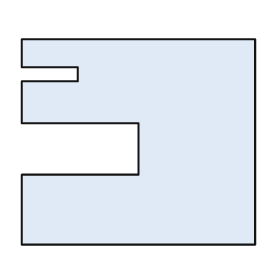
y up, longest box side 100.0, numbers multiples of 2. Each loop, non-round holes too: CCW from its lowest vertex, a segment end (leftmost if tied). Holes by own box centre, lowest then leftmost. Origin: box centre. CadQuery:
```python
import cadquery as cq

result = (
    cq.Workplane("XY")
    .moveTo(-50.0, -44.0)
    .lineTo(50.0, -44.0)
    .lineTo(50.0, 44.0)
    .lineTo(-50.0, 44.0)
    .lineTo(-50.0, 32.0)
    .lineTo(-26.0, 32.0)
    .lineTo(-26.0, 26.0)
    .lineTo(-50.0, 26.0)
    .lineTo(-50.0, 8.0)
    .lineTo(0.0, 8.0)
    .lineTo(0.0, -14.0)
    .lineTo(-50.0, -14.0)
    .close()
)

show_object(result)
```